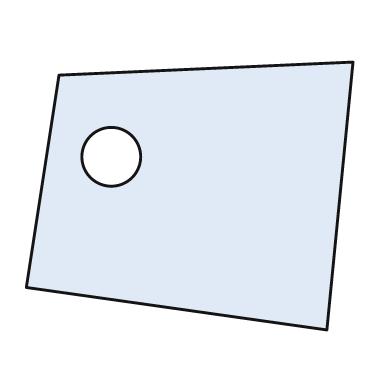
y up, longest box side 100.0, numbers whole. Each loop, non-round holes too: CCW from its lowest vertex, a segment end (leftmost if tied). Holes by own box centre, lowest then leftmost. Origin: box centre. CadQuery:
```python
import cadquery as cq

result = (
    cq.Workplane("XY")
    .moveTo(42.0, -41.0)
    .lineTo(50.0, 41.0)
    .lineTo(-40.0, 37.0)
    .lineTo(-50.0, -28.0)
    .close()
    .moveTo(-24.0, 12.0)
    .circle(9.0)
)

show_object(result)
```